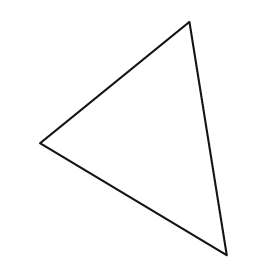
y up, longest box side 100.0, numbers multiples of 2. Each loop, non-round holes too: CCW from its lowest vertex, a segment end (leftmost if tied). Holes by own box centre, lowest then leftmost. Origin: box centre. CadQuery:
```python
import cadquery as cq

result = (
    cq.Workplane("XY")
    .moveTo(40.0, -50.0)
    .lineTo(24.0, 50.0)
    .lineTo(-40.0, -2.0)
    .close()
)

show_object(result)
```